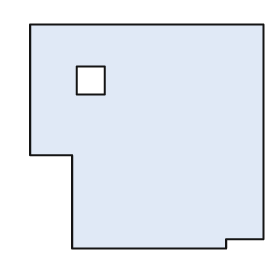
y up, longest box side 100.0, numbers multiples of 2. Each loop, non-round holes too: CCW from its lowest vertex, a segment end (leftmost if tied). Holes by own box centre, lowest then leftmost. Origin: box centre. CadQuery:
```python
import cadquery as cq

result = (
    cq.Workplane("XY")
    .moveTo(-32.0, -48.0)
    .lineTo(34.0, -48.0)
    .lineTo(34.0, -44.0)
    .lineTo(50.0, -44.0)
    .lineTo(50.0, 48.0)
    .lineTo(-50.0, 48.0)
    .lineTo(-50.0, -8.0)
    .lineTo(-32.0, -8.0)
    .close()
    .moveTo(-30.0, 18.0)
    .lineTo(-18.0, 18.0)
    .lineTo(-18.0, 30.0)
    .lineTo(-30.0, 30.0)
    .close()
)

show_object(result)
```